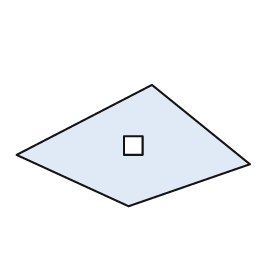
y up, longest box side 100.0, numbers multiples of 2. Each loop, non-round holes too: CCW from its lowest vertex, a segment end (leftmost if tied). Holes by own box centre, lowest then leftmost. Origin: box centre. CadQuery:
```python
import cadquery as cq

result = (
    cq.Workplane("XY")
    .moveTo(-2.0, -26.0)
    .lineTo(50.0, -8.0)
    .lineTo(8.0, 26.0)
    .lineTo(-50.0, -4.0)
    .close()
    .moveTo(-4.0, -4.0)
    .lineTo(4.0, -4.0)
    .lineTo(4.0, 4.0)
    .lineTo(-4.0, 4.0)
    .close()
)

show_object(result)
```